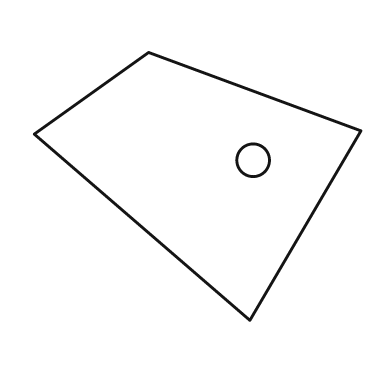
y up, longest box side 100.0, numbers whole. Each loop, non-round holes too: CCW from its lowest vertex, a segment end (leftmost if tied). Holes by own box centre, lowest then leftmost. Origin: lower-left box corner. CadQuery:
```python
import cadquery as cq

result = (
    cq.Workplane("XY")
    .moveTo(66.0, 0.0)
    .lineTo(100.0, 58.0)
    .lineTo(35.0, 82.0)
    .lineTo(0.0, 57.0)
    .close()
    .moveTo(67.0, 49.0)
    .circle(5.0)
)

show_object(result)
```